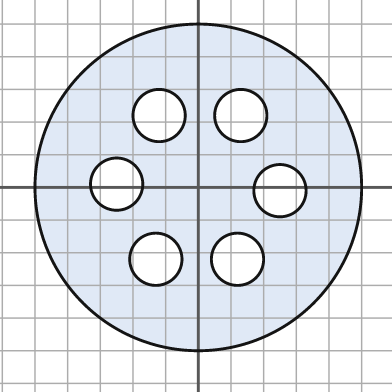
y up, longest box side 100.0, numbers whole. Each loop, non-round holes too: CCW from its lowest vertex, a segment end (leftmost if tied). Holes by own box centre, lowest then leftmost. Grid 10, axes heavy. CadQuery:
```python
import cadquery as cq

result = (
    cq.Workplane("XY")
    .moveTo(0.0, 0.0)
    .circle(50.0)
    .moveTo(-13.0, -22.0)
    .circle(8.0)
    .moveTo(12.0, -22.0)
    .circle(8.0)
    .moveTo(25.0, -1.0)
    .circle(8.0)
    .moveTo(-25.0, 1.0)
    .circle(8.0)
    .moveTo(-12.0, 22.0)
    .circle(8.0)
    .moveTo(13.0, 22.0)
    .circle(8.0)
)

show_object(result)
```